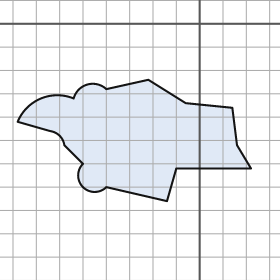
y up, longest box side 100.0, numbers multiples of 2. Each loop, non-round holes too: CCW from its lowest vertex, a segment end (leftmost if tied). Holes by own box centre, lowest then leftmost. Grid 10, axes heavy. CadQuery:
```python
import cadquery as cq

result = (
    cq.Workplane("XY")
    .moveTo(-14.0, -76.0)
    .lineTo(-10.0, -62.0)
    .lineTo(22.0, -62.0)
    .lineTo(16.0, -52.0)
    .lineTo(14.0, -36.0)
    .lineTo(-6.0, -34.0)
    .lineTo(-22.0, -24.0)
    .lineTo(-40.0, -28.0)
    .threePointArc((-48.0, -26.0), (-54.0, -32.0))
    .threePointArc((-68.0, -32.0), (-78.0, -42.0))
    .lineTo(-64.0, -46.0)
    .threePointArc((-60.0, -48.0), (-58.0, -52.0))
    .lineTo(-50.0, -60.0)
    .threePointArc((-50.0, -70.0), (-40.0, -70.0))
    .close()
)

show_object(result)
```